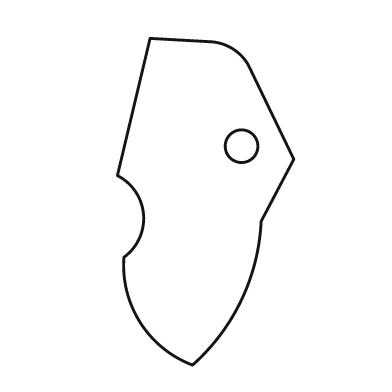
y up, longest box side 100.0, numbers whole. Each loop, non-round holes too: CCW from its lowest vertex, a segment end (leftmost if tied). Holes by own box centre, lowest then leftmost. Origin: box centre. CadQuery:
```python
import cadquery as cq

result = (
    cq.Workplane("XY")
    .moveTo(-4.0, -50.0)
    .threePointArc((11.0, -30.0), (17.0, -6.0))
    .lineTo(27.0, 13.0)
    .lineTo(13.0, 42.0)
    .threePointArc((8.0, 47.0), (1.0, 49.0))
    .lineTo(-17.0, 50.0)
    .lineTo(-27.0, 8.0)
    .threePointArc((-19.0, -4.0), (-25.0, -17.0))
    .threePointArc((-20.0, -37.0), (-4.0, -50.0))
    .close()
    .moveTo(11.0, 17.0)
    .circle(5.0)
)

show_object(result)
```